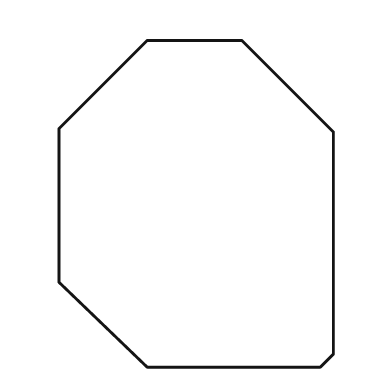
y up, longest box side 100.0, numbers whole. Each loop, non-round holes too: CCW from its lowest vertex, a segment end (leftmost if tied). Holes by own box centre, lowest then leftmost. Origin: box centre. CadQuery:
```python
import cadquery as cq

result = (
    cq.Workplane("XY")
    .moveTo(-15.0, -50.0)
    .lineTo(38.0, -50.0)
    .lineTo(42.0, -46.0)
    .lineTo(42.0, 22.0)
    .lineTo(14.0, 50.0)
    .lineTo(-15.0, 50.0)
    .lineTo(-42.0, 23.0)
    .lineTo(-42.0, -24.0)
    .close()
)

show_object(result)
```